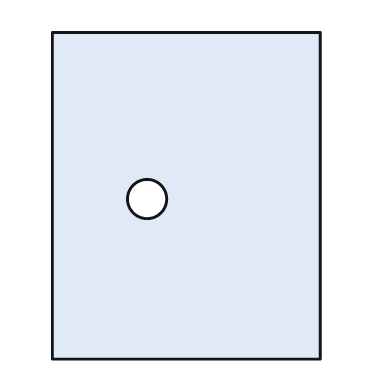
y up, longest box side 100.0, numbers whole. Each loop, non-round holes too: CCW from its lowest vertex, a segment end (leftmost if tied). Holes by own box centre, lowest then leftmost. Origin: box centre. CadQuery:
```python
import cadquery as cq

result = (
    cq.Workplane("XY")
    .moveTo(-41.0, -50.0)
    .lineTo(41.0, -50.0)
    .lineTo(41.0, 50.0)
    .lineTo(-41.0, 50.0)
    .close()
    .moveTo(-12.0, -1.0)
    .circle(6.0)
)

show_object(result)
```